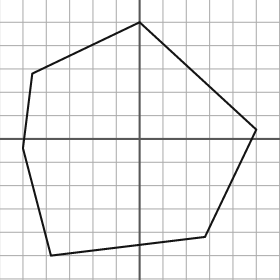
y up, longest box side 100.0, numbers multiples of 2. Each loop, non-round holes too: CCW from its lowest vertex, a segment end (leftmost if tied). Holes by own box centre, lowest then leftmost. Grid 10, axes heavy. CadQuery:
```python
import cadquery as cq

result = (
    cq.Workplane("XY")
    .moveTo(-38.0, -50.0)
    .lineTo(28.0, -42.0)
    .lineTo(50.0, 4.0)
    .lineTo(0.0, 50.0)
    .lineTo(-46.0, 28.0)
    .lineTo(-50.0, -4.0)
    .close()
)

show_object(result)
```